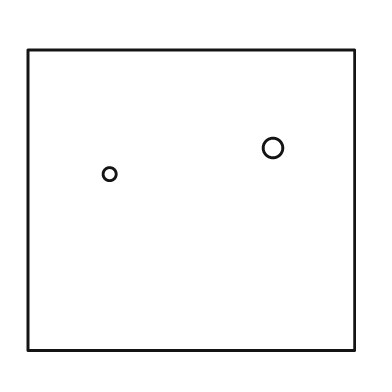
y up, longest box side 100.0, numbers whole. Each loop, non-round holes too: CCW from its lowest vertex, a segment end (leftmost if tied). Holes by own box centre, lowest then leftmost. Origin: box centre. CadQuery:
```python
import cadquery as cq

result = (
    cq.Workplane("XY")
    .moveTo(-50.0, -46.0)
    .lineTo(50.0, -46.0)
    .lineTo(50.0, 46.0)
    .lineTo(-50.0, 46.0)
    .close()
    .moveTo(-25.0, 8.0)
    .circle(2.0)
    .moveTo(25.0, 16.0)
    .circle(3.0)
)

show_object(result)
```